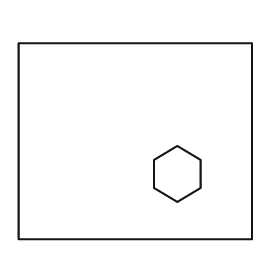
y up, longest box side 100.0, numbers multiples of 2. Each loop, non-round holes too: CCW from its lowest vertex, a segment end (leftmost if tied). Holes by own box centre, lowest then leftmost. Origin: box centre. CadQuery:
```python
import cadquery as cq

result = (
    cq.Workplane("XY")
    .moveTo(-50.0, -42.0)
    .lineTo(50.0, -42.0)
    .lineTo(50.0, 42.0)
    .lineTo(-50.0, 42.0)
    .close()
    .moveTo(18.0, -26.0)
    .lineTo(28.0, -20.0)
    .lineTo(28.0, -8.0)
    .lineTo(18.0, -2.0)
    .lineTo(8.0, -8.0)
    .lineTo(8.0, -20.0)
    .close()
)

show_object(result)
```